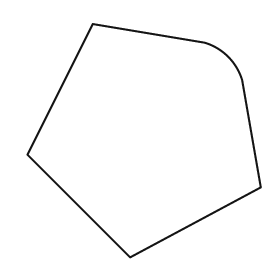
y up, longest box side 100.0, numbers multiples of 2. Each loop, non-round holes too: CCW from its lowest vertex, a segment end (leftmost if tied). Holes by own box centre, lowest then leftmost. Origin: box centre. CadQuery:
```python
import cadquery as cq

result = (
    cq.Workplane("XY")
    .moveTo(-6.0, -50.0)
    .lineTo(50.0, -20.0)
    .lineTo(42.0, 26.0)
    .threePointArc((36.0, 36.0), (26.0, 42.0))
    .lineTo(-22.0, 50.0)
    .lineTo(-50.0, -6.0)
    .close()
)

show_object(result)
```